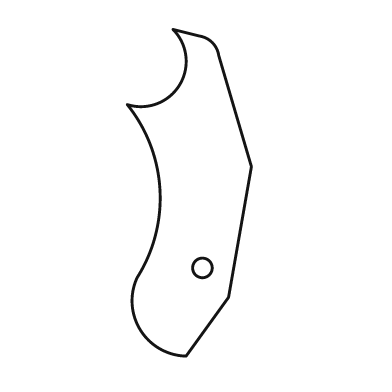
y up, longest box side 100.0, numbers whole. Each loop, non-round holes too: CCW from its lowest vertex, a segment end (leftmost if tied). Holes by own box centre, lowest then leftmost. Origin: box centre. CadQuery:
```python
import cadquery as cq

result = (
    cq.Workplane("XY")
    .moveTo(-1.0, -50.0)
    .lineTo(12.0, -32.0)
    .lineTo(19.0, 8.0)
    .lineTo(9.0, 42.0)
    .threePointArc((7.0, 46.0), (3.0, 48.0))
    .lineTo(-5.0, 50.0)
    .threePointArc((-3.0, 33.0), (-19.0, 27.0))
    .threePointArc((-9.0, 1.0), (-16.0, -26.0))
    .threePointArc((-15.0, -42.0), (-1.0, -50.0))
    .close()
    .moveTo(4.0, -23.0)
    .circle(3.0)
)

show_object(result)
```